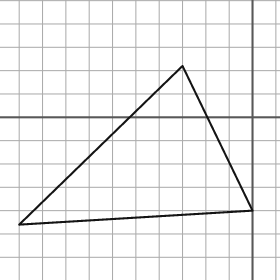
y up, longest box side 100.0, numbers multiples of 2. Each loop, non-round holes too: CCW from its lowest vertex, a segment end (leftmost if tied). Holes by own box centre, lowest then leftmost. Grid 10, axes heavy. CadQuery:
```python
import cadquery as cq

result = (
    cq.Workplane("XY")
    .moveTo(-100.0, -46.0)
    .lineTo(0.0, -40.0)
    .lineTo(-30.0, 22.0)
    .close()
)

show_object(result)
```